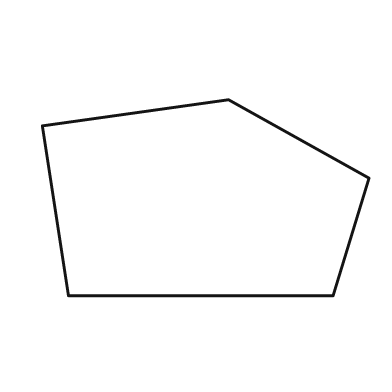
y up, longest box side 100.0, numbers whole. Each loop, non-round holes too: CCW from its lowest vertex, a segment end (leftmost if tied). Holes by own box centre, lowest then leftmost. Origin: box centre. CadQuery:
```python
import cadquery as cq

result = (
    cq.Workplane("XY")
    .moveTo(-42.0, -30.0)
    .lineTo(39.0, -30.0)
    .lineTo(50.0, 6.0)
    .lineTo(7.0, 30.0)
    .lineTo(-50.0, 22.0)
    .close()
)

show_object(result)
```